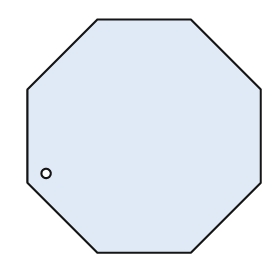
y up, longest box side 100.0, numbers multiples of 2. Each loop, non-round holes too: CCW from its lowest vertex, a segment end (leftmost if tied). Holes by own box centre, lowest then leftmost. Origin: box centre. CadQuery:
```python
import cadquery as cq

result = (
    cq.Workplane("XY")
    .moveTo(-20.0, -50.0)
    .lineTo(20.0, -50.0)
    .lineTo(50.0, -20.0)
    .lineTo(50.0, 20.0)
    .lineTo(20.0, 50.0)
    .lineTo(-20.0, 50.0)
    .lineTo(-50.0, 20.0)
    .lineTo(-50.0, -20.0)
    .close()
    .moveTo(-42.0, -16.0)
    .circle(2.0)
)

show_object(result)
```